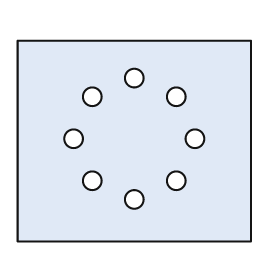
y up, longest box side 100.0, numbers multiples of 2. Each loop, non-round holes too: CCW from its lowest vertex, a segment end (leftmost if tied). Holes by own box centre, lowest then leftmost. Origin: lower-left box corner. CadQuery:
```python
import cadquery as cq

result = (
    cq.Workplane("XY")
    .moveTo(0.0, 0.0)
    .lineTo(100.0, 0.0)
    .lineTo(100.0, 86.0)
    .lineTo(0.0, 86.0)
    .close()
    .moveTo(50.0, 18.0)
    .circle(4.0)
    .moveTo(32.0, 26.0)
    .circle(4.0)
    .moveTo(68.0, 26.0)
    .circle(4.0)
    .moveTo(24.0, 44.0)
    .circle(4.0)
    .moveTo(76.0, 44.0)
    .circle(4.0)
    .moveTo(32.0, 62.0)
    .circle(4.0)
    .moveTo(68.0, 62.0)
    .circle(4.0)
    .moveTo(50.0, 70.0)
    .circle(4.0)
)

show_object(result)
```